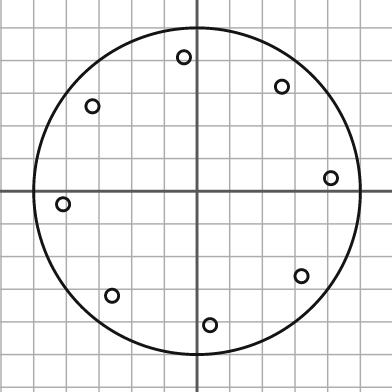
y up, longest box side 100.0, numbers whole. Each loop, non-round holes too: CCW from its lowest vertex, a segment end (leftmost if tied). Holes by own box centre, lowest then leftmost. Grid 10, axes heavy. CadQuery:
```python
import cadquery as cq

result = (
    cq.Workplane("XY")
    .moveTo(0.0, 0.0)
    .circle(50.0)
    .moveTo(4.0, -41.0)
    .circle(2.0)
    .moveTo(-26.0, -32.0)
    .circle(2.0)
    .moveTo(32.0, -26.0)
    .circle(2.0)
    .moveTo(-41.0, -4.0)
    .circle(2.0)
    .moveTo(41.0, 4.0)
    .circle(2.0)
    .moveTo(-32.0, 26.0)
    .circle(2.0)
    .moveTo(26.0, 32.0)
    .circle(2.0)
    .moveTo(-4.0, 41.0)
    .circle(2.0)
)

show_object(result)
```